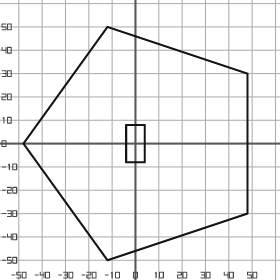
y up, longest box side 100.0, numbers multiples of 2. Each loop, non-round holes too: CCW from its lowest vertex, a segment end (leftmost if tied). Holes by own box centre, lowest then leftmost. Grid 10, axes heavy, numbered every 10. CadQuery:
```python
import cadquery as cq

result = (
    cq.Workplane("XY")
    .moveTo(-12.0, -50.0)
    .lineTo(48.0, -30.0)
    .lineTo(48.0, 30.0)
    .lineTo(-12.0, 50.0)
    .lineTo(-48.0, 0.0)
    .close()
    .moveTo(-4.0, -8.0)
    .lineTo(4.0, -8.0)
    .lineTo(4.0, 8.0)
    .lineTo(-4.0, 8.0)
    .close()
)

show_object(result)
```